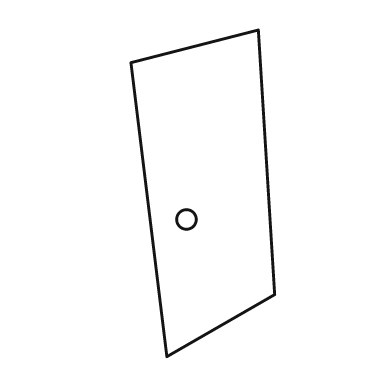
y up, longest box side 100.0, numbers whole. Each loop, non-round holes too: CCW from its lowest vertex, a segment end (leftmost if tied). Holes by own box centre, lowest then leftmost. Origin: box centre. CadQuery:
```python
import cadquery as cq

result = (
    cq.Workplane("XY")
    .moveTo(-11.0, -50.0)
    .lineTo(22.0, -31.0)
    .lineTo(17.0, 50.0)
    .lineTo(-22.0, 40.0)
    .close()
    .moveTo(-5.0, -8.0)
    .circle(3.0)
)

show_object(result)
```